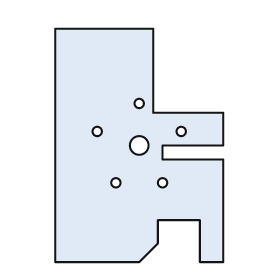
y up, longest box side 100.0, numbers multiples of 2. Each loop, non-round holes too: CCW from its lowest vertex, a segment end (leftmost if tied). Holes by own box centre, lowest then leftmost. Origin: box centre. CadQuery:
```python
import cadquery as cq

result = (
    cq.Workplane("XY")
    .moveTo(-36.0, -50.0)
    .lineTo(0.0, -50.0)
    .lineTo(8.0, -42.0)
    .lineTo(8.0, -32.0)
    .lineTo(26.0, -32.0)
    .lineTo(26.0, -50.0)
    .lineTo(36.0, -50.0)
    .lineTo(36.0, -6.0)
    .lineTo(10.0, -6.0)
    .lineTo(10.0, 0.0)
    .lineTo(36.0, 0.0)
    .lineTo(36.0, 14.0)
    .lineTo(6.0, 14.0)
    .lineTo(6.0, 50.0)
    .lineTo(-36.0, 50.0)
    .close()
    .moveTo(-10.0, -16.0)
    .circle(2.0)
    .moveTo(10.0, -16.0)
    .circle(2.0)
    .moveTo(0.0, 0.0)
    .circle(4.0)
    .moveTo(-18.0, 6.0)
    .circle(2.0)
    .moveTo(18.0, 6.0)
    .circle(2.0)
    .moveTo(0.0, 18.0)
    .circle(2.0)
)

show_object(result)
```